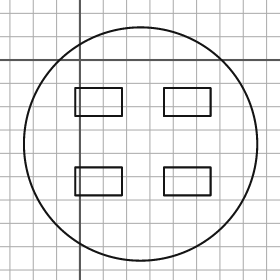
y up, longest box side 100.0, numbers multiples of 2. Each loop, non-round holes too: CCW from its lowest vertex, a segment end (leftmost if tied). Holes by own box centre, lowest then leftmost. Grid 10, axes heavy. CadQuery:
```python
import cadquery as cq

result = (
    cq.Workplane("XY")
    .moveTo(26.0, -36.0)
    .circle(50.0)
    .moveTo(-2.0, -58.0)
    .lineTo(18.0, -58.0)
    .lineTo(18.0, -46.0)
    .lineTo(-2.0, -46.0)
    .close()
    .moveTo(36.0, -58.0)
    .lineTo(56.0, -58.0)
    .lineTo(56.0, -46.0)
    .lineTo(36.0, -46.0)
    .close()
    .moveTo(-2.0, -24.0)
    .lineTo(18.0, -24.0)
    .lineTo(18.0, -12.0)
    .lineTo(-2.0, -12.0)
    .close()
    .moveTo(36.0, -24.0)
    .lineTo(56.0, -24.0)
    .lineTo(56.0, -12.0)
    .lineTo(36.0, -12.0)
    .close()
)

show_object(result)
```